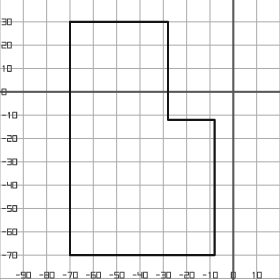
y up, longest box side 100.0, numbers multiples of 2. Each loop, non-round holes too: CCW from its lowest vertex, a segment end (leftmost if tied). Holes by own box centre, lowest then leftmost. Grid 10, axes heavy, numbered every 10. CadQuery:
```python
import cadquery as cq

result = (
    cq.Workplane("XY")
    .moveTo(-70.0, -70.0)
    .lineTo(-8.0, -70.0)
    .lineTo(-8.0, -12.0)
    .lineTo(-28.0, -12.0)
    .lineTo(-28.0, 30.0)
    .lineTo(-70.0, 30.0)
    .close()
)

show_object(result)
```